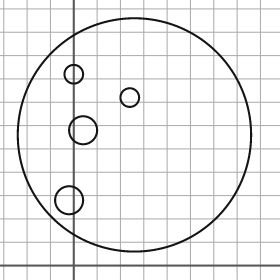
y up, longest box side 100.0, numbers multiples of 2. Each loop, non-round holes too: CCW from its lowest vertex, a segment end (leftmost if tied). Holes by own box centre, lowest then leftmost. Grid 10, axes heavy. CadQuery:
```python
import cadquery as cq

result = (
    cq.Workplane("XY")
    .moveTo(26.0, 56.0)
    .circle(50.0)
    .moveTo(-2.0, 28.0)
    .circle(6.0)
    .moveTo(4.0, 58.0)
    .circle(6.0)
    .moveTo(24.0, 72.0)
    .circle(4.0)
    .moveTo(0.0, 82.0)
    .circle(4.0)
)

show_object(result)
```